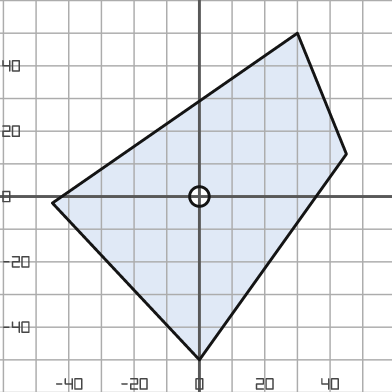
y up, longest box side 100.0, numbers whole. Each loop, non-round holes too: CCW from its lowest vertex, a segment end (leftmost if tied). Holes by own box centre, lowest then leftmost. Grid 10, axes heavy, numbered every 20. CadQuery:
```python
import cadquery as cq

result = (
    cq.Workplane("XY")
    .moveTo(0.0, -50.0)
    .lineTo(45.0, 13.0)
    .lineTo(30.0, 50.0)
    .lineTo(-45.0, -2.0)
    .close()
    .moveTo(0.0, 0.0)
    .circle(3.0)
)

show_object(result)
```